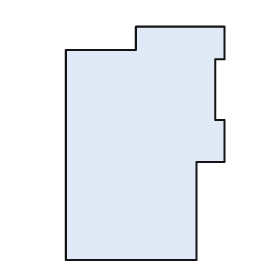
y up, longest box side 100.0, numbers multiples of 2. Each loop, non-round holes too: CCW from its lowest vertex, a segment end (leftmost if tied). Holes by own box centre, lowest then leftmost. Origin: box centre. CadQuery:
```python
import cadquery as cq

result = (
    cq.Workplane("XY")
    .moveTo(-34.0, -50.0)
    .lineTo(22.0, -50.0)
    .lineTo(22.0, -8.0)
    .lineTo(34.0, -8.0)
    .lineTo(34.0, 10.0)
    .lineTo(30.0, 10.0)
    .lineTo(30.0, 36.0)
    .lineTo(34.0, 36.0)
    .lineTo(34.0, 50.0)
    .lineTo(-4.0, 50.0)
    .lineTo(-4.0, 40.0)
    .lineTo(-34.0, 40.0)
    .close()
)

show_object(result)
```